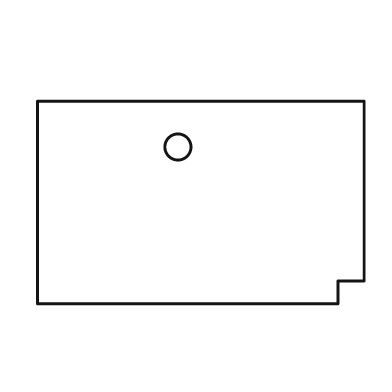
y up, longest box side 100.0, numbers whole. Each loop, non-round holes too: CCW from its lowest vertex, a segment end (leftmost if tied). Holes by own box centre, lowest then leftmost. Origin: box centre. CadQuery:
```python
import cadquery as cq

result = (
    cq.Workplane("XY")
    .moveTo(-50.0, -31.0)
    .lineTo(42.0, -31.0)
    .lineTo(42.0, -24.0)
    .lineTo(50.0, -24.0)
    .lineTo(50.0, 31.0)
    .lineTo(-50.0, 31.0)
    .close()
    .moveTo(-7.0, 17.0)
    .circle(4.0)
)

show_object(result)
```